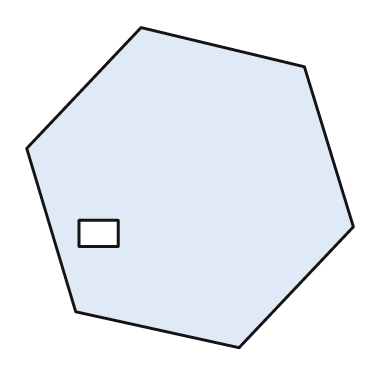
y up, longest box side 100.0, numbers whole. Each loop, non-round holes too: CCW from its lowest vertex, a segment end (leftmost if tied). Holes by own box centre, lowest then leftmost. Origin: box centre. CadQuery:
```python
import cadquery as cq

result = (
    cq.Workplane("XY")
    .moveTo(15.0, -49.0)
    .lineTo(50.0, -12.0)
    .lineTo(35.0, 37.0)
    .lineTo(-15.0, 49.0)
    .lineTo(-50.0, 12.0)
    .lineTo(-35.0, -38.0)
    .close()
    .moveTo(-34.0, -18.0)
    .lineTo(-22.0, -18.0)
    .lineTo(-22.0, -10.0)
    .lineTo(-34.0, -10.0)
    .close()
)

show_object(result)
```